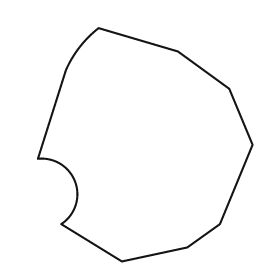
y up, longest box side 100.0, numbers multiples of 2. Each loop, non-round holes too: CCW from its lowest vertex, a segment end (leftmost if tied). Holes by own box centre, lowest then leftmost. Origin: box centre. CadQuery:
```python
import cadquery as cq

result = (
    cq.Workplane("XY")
    .moveTo(-10.0, -50.0)
    .lineTo(18.0, -44.0)
    .lineTo(32.0, -34.0)
    .lineTo(46.0, 0.0)
    .lineTo(36.0, 24.0)
    .lineTo(14.0, 40.0)
    .lineTo(-20.0, 50.0)
    .threePointArc((-28.0, 42.0), (-34.0, 32.0))
    .lineTo(-46.0, -6.0)
    .threePointArc((-30.0, -16.0), (-36.0, -34.0))
    .close()
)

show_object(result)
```